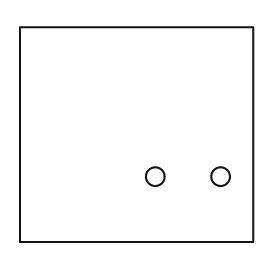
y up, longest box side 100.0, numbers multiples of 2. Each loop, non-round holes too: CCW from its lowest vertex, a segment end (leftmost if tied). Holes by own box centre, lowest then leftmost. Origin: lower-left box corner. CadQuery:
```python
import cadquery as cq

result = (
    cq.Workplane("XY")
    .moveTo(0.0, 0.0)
    .lineTo(100.0, 0.0)
    .lineTo(100.0, 92.0)
    .lineTo(0.0, 92.0)
    .close()
    .moveTo(58.0, 28.0)
    .circle(4.0)
    .moveTo(86.0, 28.0)
    .circle(4.0)
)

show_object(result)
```